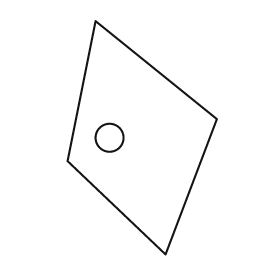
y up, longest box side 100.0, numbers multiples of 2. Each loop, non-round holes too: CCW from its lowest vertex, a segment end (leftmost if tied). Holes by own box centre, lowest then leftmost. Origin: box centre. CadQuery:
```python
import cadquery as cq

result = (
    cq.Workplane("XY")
    .moveTo(10.0, -50.0)
    .lineTo(32.0, 8.0)
    .lineTo(-20.0, 50.0)
    .lineTo(-32.0, -10.0)
    .close()
    .moveTo(-14.0, 0.0)
    .circle(6.0)
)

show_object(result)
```